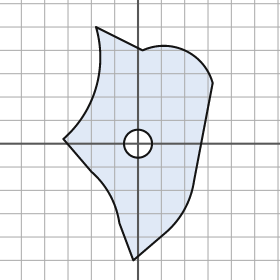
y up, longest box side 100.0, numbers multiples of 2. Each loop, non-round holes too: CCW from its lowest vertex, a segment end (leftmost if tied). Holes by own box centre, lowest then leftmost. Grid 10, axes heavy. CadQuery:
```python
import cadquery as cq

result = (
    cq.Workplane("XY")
    .moveTo(-2.0, -50.0)
    .lineTo(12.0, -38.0)
    .threePointArc((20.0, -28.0), (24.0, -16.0))
    .lineTo(32.0, 26.0)
    .threePointArc((20.0, 40.0), (2.0, 40.0))
    .lineTo(-18.0, 50.0)
    .threePointArc((-18.0, 24.0), (-32.0, 2.0))
    .lineTo(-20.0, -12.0)
    .threePointArc((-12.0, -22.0), (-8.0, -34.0))
    .close()
    .moveTo(0.0, 0.0)
    .circle(6.0)
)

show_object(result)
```